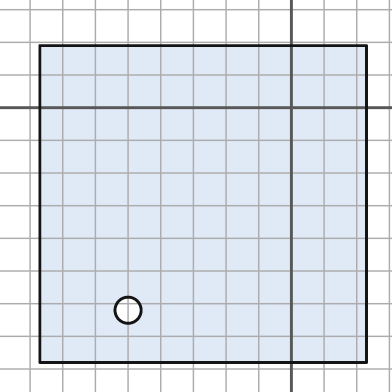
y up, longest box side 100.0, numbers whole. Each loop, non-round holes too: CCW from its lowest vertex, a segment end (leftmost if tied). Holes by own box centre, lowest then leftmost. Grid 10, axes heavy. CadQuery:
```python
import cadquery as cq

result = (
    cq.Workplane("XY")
    .moveTo(-77.0, -78.0)
    .lineTo(23.0, -78.0)
    .lineTo(23.0, 19.0)
    .lineTo(-77.0, 19.0)
    .close()
    .moveTo(-50.0, -62.0)
    .circle(4.0)
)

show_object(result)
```